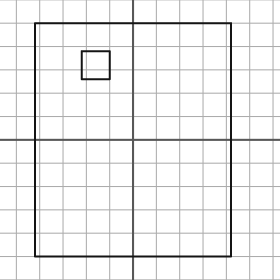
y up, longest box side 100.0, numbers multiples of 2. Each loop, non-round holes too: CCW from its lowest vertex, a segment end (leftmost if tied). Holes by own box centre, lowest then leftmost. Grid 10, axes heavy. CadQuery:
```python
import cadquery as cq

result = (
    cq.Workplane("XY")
    .moveTo(-42.0, -50.0)
    .lineTo(42.0, -50.0)
    .lineTo(42.0, 50.0)
    .lineTo(-42.0, 50.0)
    .close()
    .moveTo(-22.0, 26.0)
    .lineTo(-10.0, 26.0)
    .lineTo(-10.0, 38.0)
    .lineTo(-22.0, 38.0)
    .close()
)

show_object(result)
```